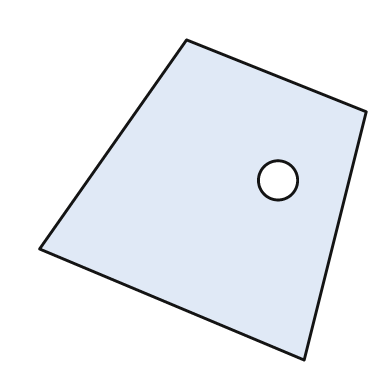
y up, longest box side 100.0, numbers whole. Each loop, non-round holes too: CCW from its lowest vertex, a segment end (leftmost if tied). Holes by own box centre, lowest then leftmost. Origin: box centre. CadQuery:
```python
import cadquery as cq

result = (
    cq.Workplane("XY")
    .moveTo(31.0, -49.0)
    .lineTo(50.0, 27.0)
    .lineTo(-5.0, 49.0)
    .lineTo(-50.0, -15.0)
    .close()
    .moveTo(23.0, 6.0)
    .circle(6.0)
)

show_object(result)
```